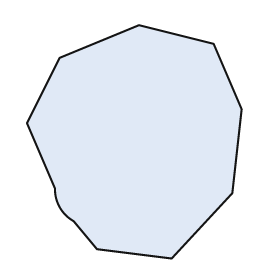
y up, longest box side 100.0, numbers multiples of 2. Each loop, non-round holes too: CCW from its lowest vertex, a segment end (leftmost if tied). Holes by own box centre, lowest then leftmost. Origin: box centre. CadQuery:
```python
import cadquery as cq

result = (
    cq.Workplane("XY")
    .moveTo(16.0, -50.0)
    .lineTo(42.0, -22.0)
    .lineTo(46.0, 14.0)
    .lineTo(34.0, 42.0)
    .lineTo(2.0, 50.0)
    .lineTo(-32.0, 36.0)
    .lineTo(-46.0, 8.0)
    .lineTo(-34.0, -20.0)
    .threePointArc((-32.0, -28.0), (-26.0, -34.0))
    .lineTo(-16.0, -46.0)
    .close()
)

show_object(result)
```